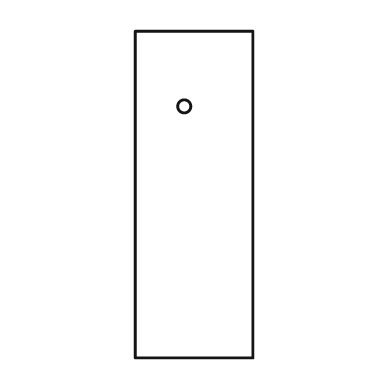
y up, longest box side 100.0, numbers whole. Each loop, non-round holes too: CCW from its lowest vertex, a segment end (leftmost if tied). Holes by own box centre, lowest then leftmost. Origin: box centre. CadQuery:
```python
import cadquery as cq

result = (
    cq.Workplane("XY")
    .moveTo(-18.0, -50.0)
    .lineTo(18.0, -50.0)
    .lineTo(18.0, 50.0)
    .lineTo(-18.0, 50.0)
    .close()
    .moveTo(-3.0, 27.0)
    .circle(2.0)
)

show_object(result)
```